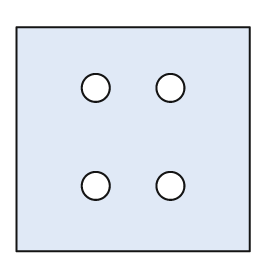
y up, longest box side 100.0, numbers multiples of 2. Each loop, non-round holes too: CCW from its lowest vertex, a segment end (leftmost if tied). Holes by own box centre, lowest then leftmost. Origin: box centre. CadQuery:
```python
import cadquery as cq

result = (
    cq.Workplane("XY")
    .moveTo(-50.0, -48.0)
    .lineTo(50.0, -48.0)
    .lineTo(50.0, 48.0)
    .lineTo(-50.0, 48.0)
    .close()
    .moveTo(-16.0, -20.0)
    .circle(6.0)
    .moveTo(16.0, -20.0)
    .circle(6.0)
    .moveTo(-16.0, 22.0)
    .circle(6.0)
    .moveTo(16.0, 22.0)
    .circle(6.0)
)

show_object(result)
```